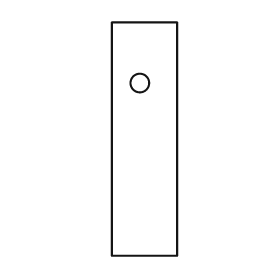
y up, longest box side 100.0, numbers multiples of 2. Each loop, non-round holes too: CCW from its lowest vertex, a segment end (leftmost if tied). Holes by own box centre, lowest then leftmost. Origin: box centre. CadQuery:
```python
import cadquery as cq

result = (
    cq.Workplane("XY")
    .moveTo(-14.0, -50.0)
    .lineTo(14.0, -50.0)
    .lineTo(14.0, 50.0)
    .lineTo(-14.0, 50.0)
    .close()
    .moveTo(-2.0, 24.0)
    .circle(4.0)
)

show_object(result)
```